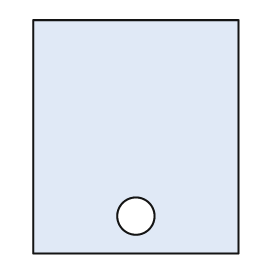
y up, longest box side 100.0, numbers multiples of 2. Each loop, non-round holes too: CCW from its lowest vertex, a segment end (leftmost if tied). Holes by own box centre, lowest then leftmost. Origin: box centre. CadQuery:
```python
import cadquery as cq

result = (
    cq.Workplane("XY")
    .moveTo(-44.0, -50.0)
    .lineTo(44.0, -50.0)
    .lineTo(44.0, 50.0)
    .lineTo(-44.0, 50.0)
    .close()
    .moveTo(0.0, -34.0)
    .circle(8.0)
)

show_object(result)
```